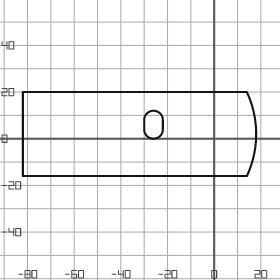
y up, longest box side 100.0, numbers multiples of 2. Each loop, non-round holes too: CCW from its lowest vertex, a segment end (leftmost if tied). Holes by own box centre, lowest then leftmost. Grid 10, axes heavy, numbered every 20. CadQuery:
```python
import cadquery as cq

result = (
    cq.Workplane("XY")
    .moveTo(-82.0, -16.0)
    .lineTo(14.0, -16.0)
    .threePointArc((18.0, 2.0), (14.0, 20.0))
    .lineTo(-82.0, 20.0)
    .close()
    .moveTo(-30.0, 4.0)
    .threePointArc((-26.0, 0.0), (-22.0, 4.0))
    .lineTo(-22.0, 8.0)
    .threePointArc((-26.0, 12.0), (-30.0, 8.0))
    .close()
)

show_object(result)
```